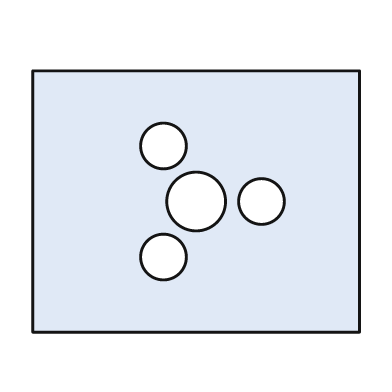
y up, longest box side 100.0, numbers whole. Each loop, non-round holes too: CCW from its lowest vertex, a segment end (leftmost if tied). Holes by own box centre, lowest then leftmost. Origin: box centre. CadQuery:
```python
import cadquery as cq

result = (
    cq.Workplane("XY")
    .moveTo(-50.0, -40.0)
    .lineTo(50.0, -40.0)
    .lineTo(50.0, 40.0)
    .lineTo(-50.0, 40.0)
    .close()
    .moveTo(-10.0, -17.0)
    .circle(7.0)
    .moveTo(0.0, 0.0)
    .circle(9.0)
    .moveTo(20.0, 0.0)
    .circle(7.0)
    .moveTo(-10.0, 17.0)
    .circle(7.0)
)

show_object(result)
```